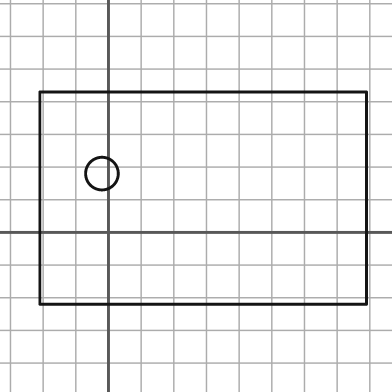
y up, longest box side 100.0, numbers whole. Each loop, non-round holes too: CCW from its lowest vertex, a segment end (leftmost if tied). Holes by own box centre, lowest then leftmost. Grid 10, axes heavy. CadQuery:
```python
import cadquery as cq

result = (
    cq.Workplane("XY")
    .moveTo(-21.0, -22.0)
    .lineTo(79.0, -22.0)
    .lineTo(79.0, 43.0)
    .lineTo(-21.0, 43.0)
    .close()
    .moveTo(-2.0, 18.0)
    .circle(5.0)
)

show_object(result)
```